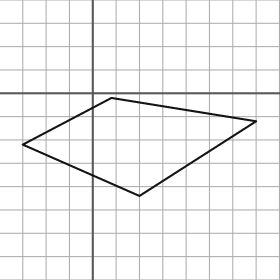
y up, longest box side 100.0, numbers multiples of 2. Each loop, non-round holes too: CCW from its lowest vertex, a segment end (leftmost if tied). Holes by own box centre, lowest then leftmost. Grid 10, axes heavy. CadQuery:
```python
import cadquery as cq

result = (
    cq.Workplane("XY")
    .moveTo(20.0, -44.0)
    .lineTo(70.0, -12.0)
    .lineTo(8.0, -2.0)
    .lineTo(-30.0, -22.0)
    .close()
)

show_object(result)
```